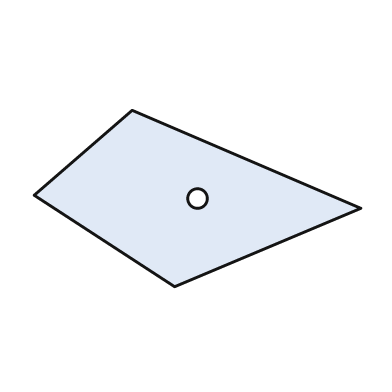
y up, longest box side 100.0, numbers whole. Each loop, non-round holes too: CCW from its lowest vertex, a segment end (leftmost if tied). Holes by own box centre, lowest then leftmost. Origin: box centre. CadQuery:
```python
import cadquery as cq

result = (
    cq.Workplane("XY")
    .moveTo(-7.0, -27.0)
    .lineTo(50.0, -3.0)
    .lineTo(-20.0, 27.0)
    .lineTo(-50.0, 1.0)
    .close()
    .moveTo(0.0, 0.0)
    .circle(3.0)
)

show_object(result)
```